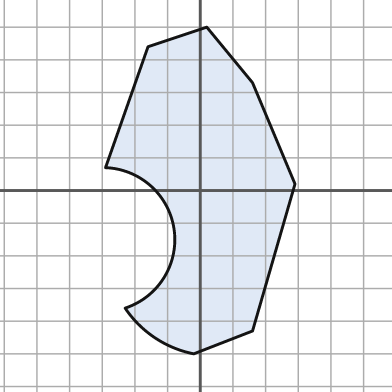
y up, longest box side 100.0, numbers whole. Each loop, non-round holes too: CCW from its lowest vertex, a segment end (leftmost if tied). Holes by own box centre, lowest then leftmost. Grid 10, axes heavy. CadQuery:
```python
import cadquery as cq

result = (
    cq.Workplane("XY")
    .moveTo(-2.0, -50.0)
    .lineTo(16.0, -43.0)
    .lineTo(29.0, 2.0)
    .lineTo(16.0, 33.0)
    .lineTo(2.0, 50.0)
    .lineTo(-16.0, 44.0)
    .lineTo(-29.0, 7.0)
    .threePointArc((-8.0, -12.0), (-23.0, -36.0))
    .threePointArc((-14.0, -45.0), (-2.0, -50.0))
    .close()
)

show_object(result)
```